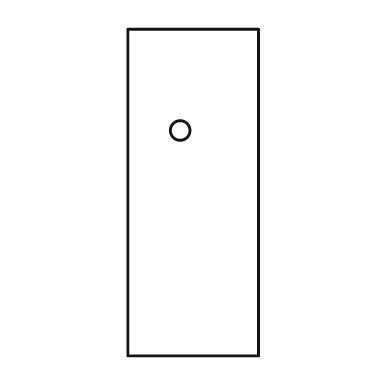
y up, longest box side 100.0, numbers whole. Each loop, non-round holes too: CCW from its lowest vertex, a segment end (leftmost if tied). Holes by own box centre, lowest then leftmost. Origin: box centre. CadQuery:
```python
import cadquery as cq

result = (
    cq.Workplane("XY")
    .moveTo(-20.0, -50.0)
    .lineTo(20.0, -50.0)
    .lineTo(20.0, 50.0)
    .lineTo(-20.0, 50.0)
    .close()
    .moveTo(-4.0, 19.0)
    .circle(3.0)
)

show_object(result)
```